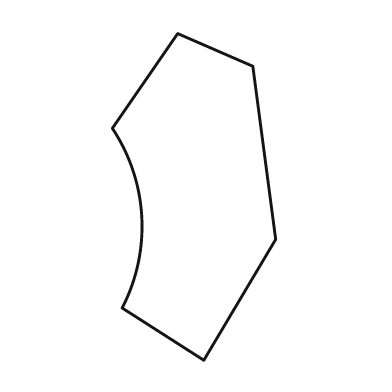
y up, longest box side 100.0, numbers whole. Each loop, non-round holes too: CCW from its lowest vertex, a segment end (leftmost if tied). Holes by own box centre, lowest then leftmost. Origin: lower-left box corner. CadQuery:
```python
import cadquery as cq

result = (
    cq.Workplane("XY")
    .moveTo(28.0, 0.0)
    .lineTo(50.0, 37.0)
    .lineTo(43.0, 90.0)
    .lineTo(20.0, 100.0)
    .lineTo(0.0, 71.0)
    .threePointArc((9.0, 44.0), (3.0, 16.0))
    .close()
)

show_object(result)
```